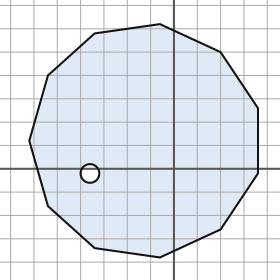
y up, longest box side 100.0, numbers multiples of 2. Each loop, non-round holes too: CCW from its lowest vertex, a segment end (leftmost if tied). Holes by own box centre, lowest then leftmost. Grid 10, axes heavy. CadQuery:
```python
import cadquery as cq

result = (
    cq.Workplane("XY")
    .moveTo(-6.0, -38.0)
    .lineTo(20.0, -26.0)
    .lineTo(36.0, -2.0)
    .lineTo(36.0, 26.0)
    .lineTo(20.0, 50.0)
    .lineTo(-6.0, 62.0)
    .lineTo(-34.0, 58.0)
    .lineTo(-54.0, 40.0)
    .lineTo(-62.0, 12.0)
    .lineTo(-54.0, -16.0)
    .lineTo(-34.0, -34.0)
    .close()
    .moveTo(-36.0, -2.0)
    .circle(4.0)
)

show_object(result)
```